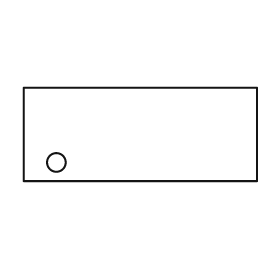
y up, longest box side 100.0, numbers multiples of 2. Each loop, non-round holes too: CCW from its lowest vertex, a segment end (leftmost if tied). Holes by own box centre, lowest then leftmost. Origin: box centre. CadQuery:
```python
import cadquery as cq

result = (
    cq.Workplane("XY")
    .moveTo(-50.0, -20.0)
    .lineTo(50.0, -20.0)
    .lineTo(50.0, 20.0)
    .lineTo(-50.0, 20.0)
    .close()
    .moveTo(-36.0, -12.0)
    .circle(4.0)
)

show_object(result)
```